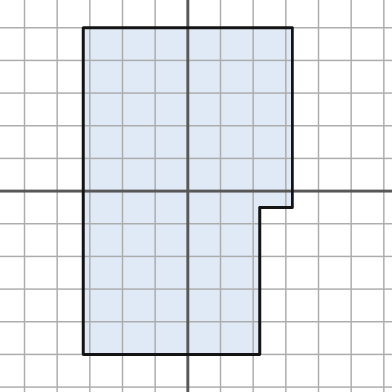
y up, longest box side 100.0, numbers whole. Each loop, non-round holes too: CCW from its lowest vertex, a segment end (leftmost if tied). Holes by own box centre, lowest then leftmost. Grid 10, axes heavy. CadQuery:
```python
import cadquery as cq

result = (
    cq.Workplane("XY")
    .moveTo(-32.0, -50.0)
    .lineTo(22.0, -50.0)
    .lineTo(22.0, -5.0)
    .lineTo(32.0, -5.0)
    .lineTo(32.0, 50.0)
    .lineTo(-32.0, 50.0)
    .close()
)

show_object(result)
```